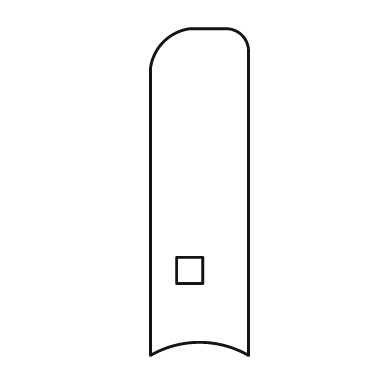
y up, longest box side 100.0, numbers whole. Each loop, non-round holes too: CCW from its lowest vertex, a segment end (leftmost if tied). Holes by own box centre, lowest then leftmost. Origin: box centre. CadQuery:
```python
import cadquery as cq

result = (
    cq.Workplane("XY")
    .moveTo(-15.0, -50.0)
    .threePointArc((0.0, -46.0), (15.0, -50.0))
    .lineTo(15.0, 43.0)
    .threePointArc((13.0, 48.0), (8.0, 50.0))
    .lineTo(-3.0, 50.0)
    .threePointArc((-11.0, 46.0), (-15.0, 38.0))
    .close()
    .moveTo(-7.0, -28.0)
    .lineTo(1.0, -28.0)
    .lineTo(1.0, -20.0)
    .lineTo(-7.0, -20.0)
    .close()
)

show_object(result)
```